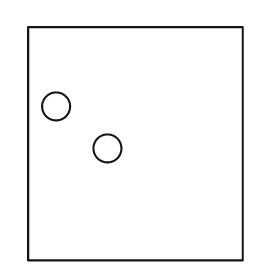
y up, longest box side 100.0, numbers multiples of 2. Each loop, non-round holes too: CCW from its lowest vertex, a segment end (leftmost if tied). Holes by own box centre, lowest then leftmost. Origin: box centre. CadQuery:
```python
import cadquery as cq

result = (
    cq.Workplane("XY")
    .moveTo(-46.0, -50.0)
    .lineTo(46.0, -50.0)
    .lineTo(46.0, 50.0)
    .lineTo(-46.0, 50.0)
    .close()
    .moveTo(-12.0, -2.0)
    .circle(6.0)
    .moveTo(-34.0, 16.0)
    .circle(6.0)
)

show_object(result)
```